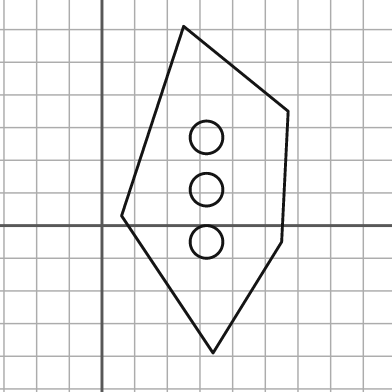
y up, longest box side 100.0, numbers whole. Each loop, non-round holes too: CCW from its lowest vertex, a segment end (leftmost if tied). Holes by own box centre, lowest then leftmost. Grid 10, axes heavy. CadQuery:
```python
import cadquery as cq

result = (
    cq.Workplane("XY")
    .moveTo(34.0, -39.0)
    .lineTo(55.0, -5.0)
    .lineTo(57.0, 35.0)
    .lineTo(25.0, 61.0)
    .lineTo(6.0, 3.0)
    .close()
    .moveTo(32.0, -5.0)
    .circle(5.0)
    .moveTo(32.0, 11.0)
    .circle(5.0)
    .moveTo(32.0, 27.0)
    .circle(5.0)
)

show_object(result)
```